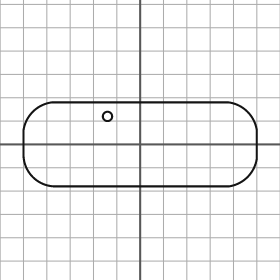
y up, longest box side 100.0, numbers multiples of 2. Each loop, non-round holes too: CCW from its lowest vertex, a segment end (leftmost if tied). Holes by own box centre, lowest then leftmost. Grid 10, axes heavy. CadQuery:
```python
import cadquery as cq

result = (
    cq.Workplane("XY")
    .moveTo(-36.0, -18.0)
    .lineTo(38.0, -18.0)
    .threePointArc((46.0, -14.0), (50.0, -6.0))
    .lineTo(50.0, 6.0)
    .threePointArc((46.0, 14.0), (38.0, 18.0))
    .lineTo(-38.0, 18.0)
    .threePointArc((-46.0, 14.0), (-50.0, 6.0))
    .lineTo(-50.0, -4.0)
    .threePointArc((-46.0, -14.0), (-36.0, -18.0))
    .close()
    .moveTo(-14.0, 12.0)
    .circle(2.0)
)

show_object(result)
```